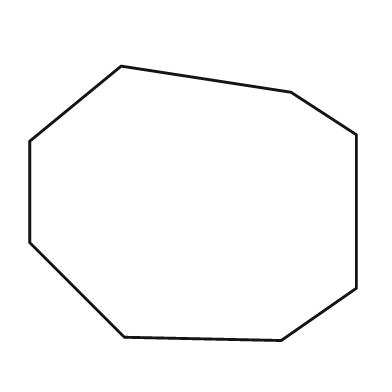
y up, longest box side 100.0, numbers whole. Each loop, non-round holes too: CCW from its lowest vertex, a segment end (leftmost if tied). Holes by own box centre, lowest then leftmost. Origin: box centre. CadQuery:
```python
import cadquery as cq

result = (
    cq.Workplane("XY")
    .moveTo(27.0, -42.0)
    .lineTo(50.0, -26.0)
    .lineTo(50.0, 21.0)
    .lineTo(30.0, 34.0)
    .lineTo(-22.0, 42.0)
    .lineTo(-50.0, 19.0)
    .lineTo(-50.0, -12.0)
    .lineTo(-21.0, -41.0)
    .close()
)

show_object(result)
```